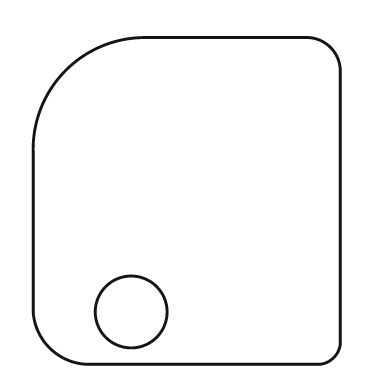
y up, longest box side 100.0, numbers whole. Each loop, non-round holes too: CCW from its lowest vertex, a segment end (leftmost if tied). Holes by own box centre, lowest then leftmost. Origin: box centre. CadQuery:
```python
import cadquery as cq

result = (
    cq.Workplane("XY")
    .moveTo(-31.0, -50.0)
    .lineTo(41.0, -50.0)
    .threePointArc((45.0, -48.0), (47.0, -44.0))
    .lineTo(47.0, 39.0)
    .threePointArc((44.0, 47.0), (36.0, 50.0))
    .lineTo(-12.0, 50.0)
    .threePointArc((-37.0, 40.0), (-47.0, 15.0))
    .lineTo(-47.0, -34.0)
    .threePointArc((-42.0, -45.0), (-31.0, -50.0))
    .close()
    .moveTo(-17.0, -34.0)
    .circle(11.0)
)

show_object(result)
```